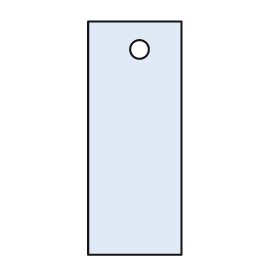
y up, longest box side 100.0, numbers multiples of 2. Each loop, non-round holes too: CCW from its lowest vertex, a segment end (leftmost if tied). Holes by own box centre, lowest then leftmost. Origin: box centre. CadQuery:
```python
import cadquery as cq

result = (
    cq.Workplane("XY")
    .moveTo(-20.0, -50.0)
    .lineTo(20.0, -50.0)
    .lineTo(20.0, 50.0)
    .lineTo(-20.0, 50.0)
    .close()
    .moveTo(2.0, 38.0)
    .circle(4.0)
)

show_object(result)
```